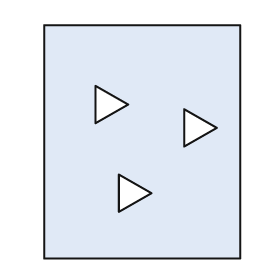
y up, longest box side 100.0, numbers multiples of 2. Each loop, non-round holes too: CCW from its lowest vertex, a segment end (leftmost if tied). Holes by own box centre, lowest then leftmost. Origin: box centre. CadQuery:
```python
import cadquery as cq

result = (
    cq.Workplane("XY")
    .moveTo(-42.0, -50.0)
    .lineTo(42.0, -50.0)
    .lineTo(42.0, 50.0)
    .lineTo(-42.0, 50.0)
    .close()
    .moveTo(-10.0, -30.0)
    .lineTo(4.0, -22.0)
    .lineTo(-10.0, -14.0)
    .close()
    .moveTo(18.0, -2.0)
    .lineTo(32.0, 6.0)
    .lineTo(18.0, 14.0)
    .close()
    .moveTo(-20.0, 8.0)
    .lineTo(-6.0, 16.0)
    .lineTo(-20.0, 24.0)
    .close()
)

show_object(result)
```